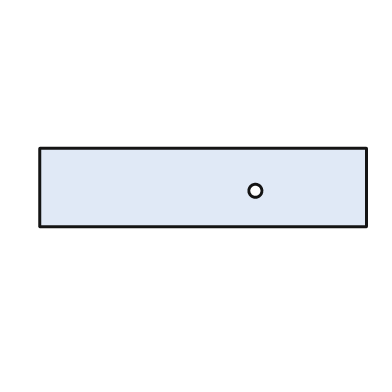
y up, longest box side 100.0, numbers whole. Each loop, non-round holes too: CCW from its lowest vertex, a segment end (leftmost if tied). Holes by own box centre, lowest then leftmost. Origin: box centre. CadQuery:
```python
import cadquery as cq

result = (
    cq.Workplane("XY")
    .moveTo(-50.0, -12.0)
    .lineTo(50.0, -12.0)
    .lineTo(50.0, 12.0)
    .lineTo(-50.0, 12.0)
    .close()
    .moveTo(16.0, -1.0)
    .circle(2.0)
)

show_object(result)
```